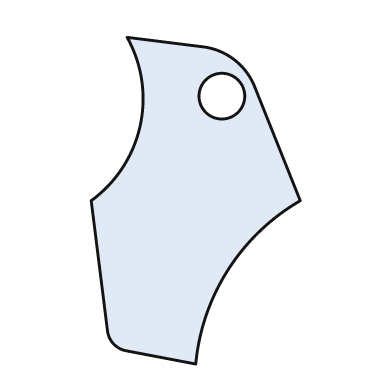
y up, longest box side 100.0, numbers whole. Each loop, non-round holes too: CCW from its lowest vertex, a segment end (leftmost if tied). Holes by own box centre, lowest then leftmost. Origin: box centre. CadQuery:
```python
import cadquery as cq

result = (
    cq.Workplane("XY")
    .moveTo(0.0, -50.0)
    .threePointArc((10.0, -21.0), (32.0, 0.0))
    .lineTo(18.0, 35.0)
    .threePointArc((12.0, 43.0), (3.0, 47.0))
    .lineTo(-21.0, 50.0)
    .threePointArc((-17.0, 23.0), (-32.0, 0.0))
    .lineTo(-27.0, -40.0)
    .threePointArc((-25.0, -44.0), (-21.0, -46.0))
    .close()
    .moveTo(8.0, 32.0)
    .circle(7.0)
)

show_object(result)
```